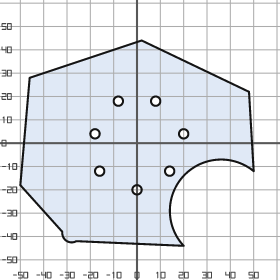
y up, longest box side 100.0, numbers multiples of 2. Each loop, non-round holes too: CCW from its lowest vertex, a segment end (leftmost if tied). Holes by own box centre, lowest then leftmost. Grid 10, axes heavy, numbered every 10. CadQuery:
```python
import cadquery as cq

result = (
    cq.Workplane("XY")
    .moveTo(20.0, -44.0)
    .threePointArc((20.0, -14.0), (50.0, -12.0))
    .lineTo(48.0, 22.0)
    .lineTo(2.0, 44.0)
    .lineTo(-46.0, 28.0)
    .lineTo(-50.0, -18.0)
    .lineTo(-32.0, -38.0)
    .threePointArc((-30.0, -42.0), (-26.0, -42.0))
    .close()
    .moveTo(0.0, -20.0)
    .circle(2.0)
    .moveTo(-16.0, -12.0)
    .circle(2.0)
    .moveTo(14.0, -12.0)
    .circle(2.0)
    .moveTo(-18.0, 4.0)
    .circle(2.0)
    .moveTo(20.0, 4.0)
    .circle(2.0)
    .moveTo(-8.0, 18.0)
    .circle(2.0)
    .moveTo(8.0, 18.0)
    .circle(2.0)
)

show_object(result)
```